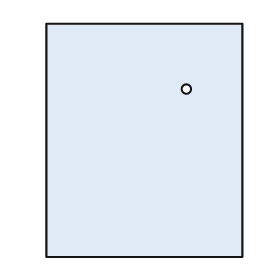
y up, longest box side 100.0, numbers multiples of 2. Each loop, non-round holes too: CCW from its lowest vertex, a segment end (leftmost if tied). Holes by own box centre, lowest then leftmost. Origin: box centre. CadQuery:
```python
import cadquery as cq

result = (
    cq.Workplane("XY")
    .moveTo(-42.0, -50.0)
    .lineTo(42.0, -50.0)
    .lineTo(42.0, 50.0)
    .lineTo(-42.0, 50.0)
    .close()
    .moveTo(18.0, 22.0)
    .circle(2.0)
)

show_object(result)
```